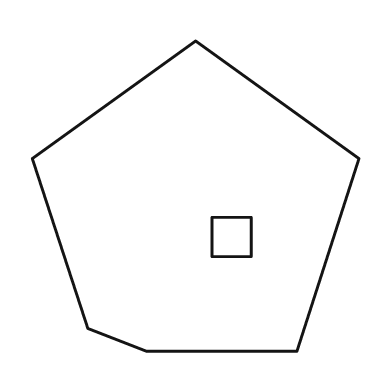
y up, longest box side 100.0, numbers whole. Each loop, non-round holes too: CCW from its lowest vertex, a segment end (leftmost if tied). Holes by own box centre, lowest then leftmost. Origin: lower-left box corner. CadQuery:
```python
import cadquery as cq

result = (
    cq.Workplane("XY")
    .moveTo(35.0, 0.0)
    .lineTo(81.0, 0.0)
    .lineTo(100.0, 59.0)
    .lineTo(50.0, 95.0)
    .lineTo(0.0, 59.0)
    .lineTo(17.0, 7.0)
    .close()
    .moveTo(55.0, 29.0)
    .lineTo(67.0, 29.0)
    .lineTo(67.0, 41.0)
    .lineTo(55.0, 41.0)
    .close()
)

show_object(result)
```